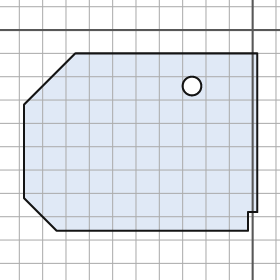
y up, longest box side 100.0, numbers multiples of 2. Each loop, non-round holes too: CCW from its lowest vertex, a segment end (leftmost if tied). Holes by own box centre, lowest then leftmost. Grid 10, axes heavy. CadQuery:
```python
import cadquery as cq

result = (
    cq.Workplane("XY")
    .moveTo(-84.0, -86.0)
    .lineTo(-2.0, -86.0)
    .lineTo(-2.0, -78.0)
    .lineTo(2.0, -78.0)
    .lineTo(2.0, -10.0)
    .lineTo(-76.0, -10.0)
    .lineTo(-98.0, -32.0)
    .lineTo(-98.0, -72.0)
    .close()
    .moveTo(-26.0, -24.0)
    .circle(4.0)
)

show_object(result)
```